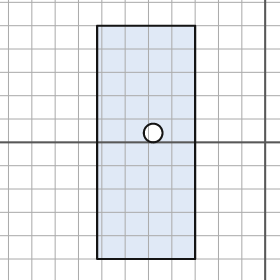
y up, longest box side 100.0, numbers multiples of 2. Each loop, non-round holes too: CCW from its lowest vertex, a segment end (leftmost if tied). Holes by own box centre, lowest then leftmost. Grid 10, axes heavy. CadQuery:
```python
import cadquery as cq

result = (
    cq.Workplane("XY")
    .moveTo(-72.0, -50.0)
    .lineTo(-30.0, -50.0)
    .lineTo(-30.0, 50.0)
    .lineTo(-72.0, 50.0)
    .close()
    .moveTo(-48.0, 4.0)
    .circle(4.0)
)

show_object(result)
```